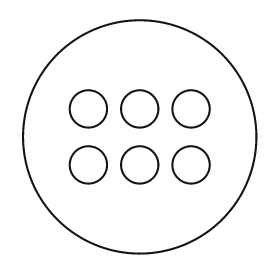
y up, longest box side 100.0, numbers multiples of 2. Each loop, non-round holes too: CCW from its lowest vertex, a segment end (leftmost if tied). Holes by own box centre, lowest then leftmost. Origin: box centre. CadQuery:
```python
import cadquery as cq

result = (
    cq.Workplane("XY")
    .moveTo(0.0, 0.0)
    .circle(50.0)
    .moveTo(-22.0, -12.0)
    .circle(8.0)
    .moveTo(0.0, -12.0)
    .circle(8.0)
    .moveTo(22.0, -12.0)
    .circle(8.0)
    .moveTo(-22.0, 12.0)
    .circle(8.0)
    .moveTo(0.0, 12.0)
    .circle(8.0)
    .moveTo(22.0, 12.0)
    .circle(8.0)
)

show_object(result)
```